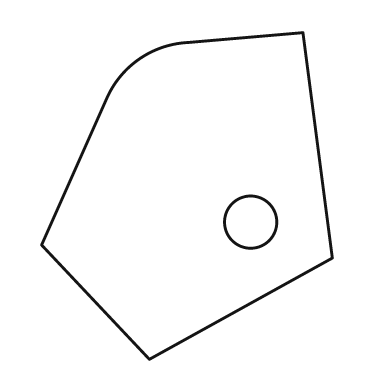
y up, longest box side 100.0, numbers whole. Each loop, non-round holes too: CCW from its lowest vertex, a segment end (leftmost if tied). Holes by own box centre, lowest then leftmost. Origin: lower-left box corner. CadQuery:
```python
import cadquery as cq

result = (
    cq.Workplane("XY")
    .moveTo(33.0, 0.0)
    .lineTo(89.0, 31.0)
    .lineTo(80.0, 100.0)
    .lineTo(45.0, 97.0)
    .threePointArc((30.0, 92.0), (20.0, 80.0))
    .lineTo(0.0, 35.0)
    .close()
    .moveTo(64.0, 42.0)
    .circle(8.0)
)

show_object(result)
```